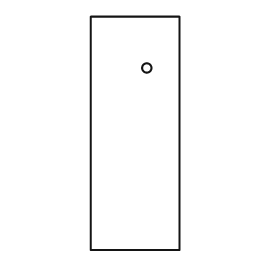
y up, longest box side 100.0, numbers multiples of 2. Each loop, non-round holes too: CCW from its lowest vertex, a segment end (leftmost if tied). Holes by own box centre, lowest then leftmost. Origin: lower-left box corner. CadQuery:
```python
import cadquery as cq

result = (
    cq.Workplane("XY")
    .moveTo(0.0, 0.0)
    .lineTo(38.0, 0.0)
    .lineTo(38.0, 100.0)
    .lineTo(0.0, 100.0)
    .close()
    .moveTo(24.0, 78.0)
    .circle(2.0)
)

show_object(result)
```